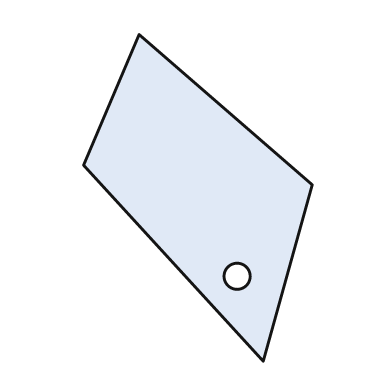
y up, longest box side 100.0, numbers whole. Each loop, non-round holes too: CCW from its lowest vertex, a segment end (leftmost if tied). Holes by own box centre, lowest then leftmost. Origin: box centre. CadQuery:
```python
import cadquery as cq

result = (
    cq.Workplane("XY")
    .moveTo(20.0, -50.0)
    .lineTo(35.0, 4.0)
    .lineTo(-18.0, 50.0)
    .lineTo(-35.0, 10.0)
    .close()
    .moveTo(12.0, -24.0)
    .circle(4.0)
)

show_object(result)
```